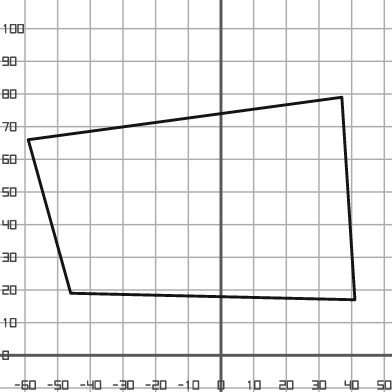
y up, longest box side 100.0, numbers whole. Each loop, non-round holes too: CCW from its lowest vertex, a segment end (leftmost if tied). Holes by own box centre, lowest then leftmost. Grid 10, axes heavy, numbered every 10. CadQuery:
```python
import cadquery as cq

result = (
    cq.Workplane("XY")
    .moveTo(41.0, 17.0)
    .lineTo(37.0, 79.0)
    .lineTo(-59.0, 66.0)
    .lineTo(-46.0, 19.0)
    .close()
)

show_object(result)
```